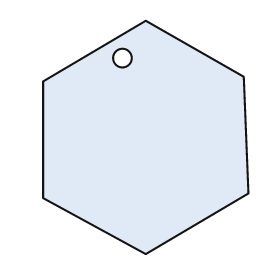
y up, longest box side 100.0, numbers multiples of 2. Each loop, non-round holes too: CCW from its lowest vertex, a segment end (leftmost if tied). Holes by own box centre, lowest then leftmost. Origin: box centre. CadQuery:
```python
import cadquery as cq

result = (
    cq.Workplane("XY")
    .moveTo(0.0, -50.0)
    .lineTo(44.0, -24.0)
    .lineTo(42.0, 26.0)
    .lineTo(0.0, 50.0)
    .lineTo(-44.0, 24.0)
    .lineTo(-44.0, -26.0)
    .close()
    .moveTo(-10.0, 34.0)
    .circle(4.0)
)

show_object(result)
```